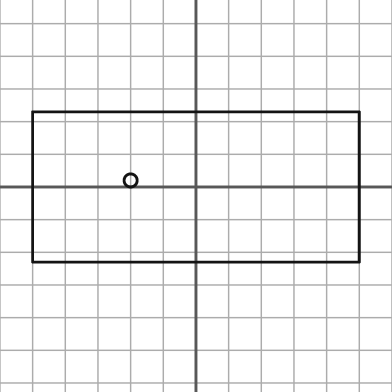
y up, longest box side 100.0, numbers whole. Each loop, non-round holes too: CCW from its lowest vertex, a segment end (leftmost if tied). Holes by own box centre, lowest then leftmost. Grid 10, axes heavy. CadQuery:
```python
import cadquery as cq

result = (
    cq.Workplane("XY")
    .moveTo(-50.0, -23.0)
    .lineTo(50.0, -23.0)
    .lineTo(50.0, 23.0)
    .lineTo(-50.0, 23.0)
    .close()
    .moveTo(-20.0, 2.0)
    .circle(2.0)
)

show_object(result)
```